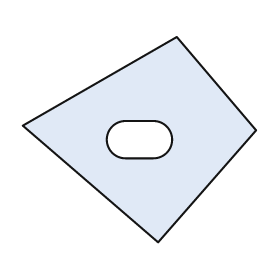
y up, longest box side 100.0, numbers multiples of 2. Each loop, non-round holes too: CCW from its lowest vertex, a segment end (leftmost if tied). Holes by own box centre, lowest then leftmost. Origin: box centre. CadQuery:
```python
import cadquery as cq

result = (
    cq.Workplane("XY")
    .moveTo(8.0, -44.0)
    .lineTo(50.0, 4.0)
    .lineTo(16.0, 44.0)
    .lineTo(-50.0, 6.0)
    .close()
    .moveTo(-6.0, -8.0)
    .lineTo(6.0, -8.0)
    .threePointArc((14.0, 0.0), (6.0, 8.0))
    .lineTo(-6.0, 8.0)
    .threePointArc((-14.0, 0.0), (-6.0, -8.0))
    .close()
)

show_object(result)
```